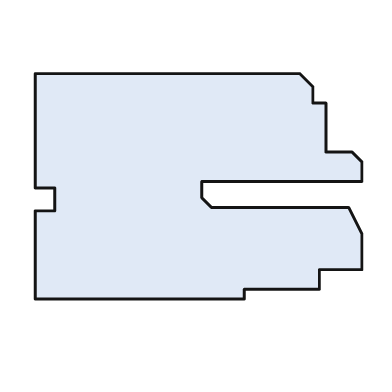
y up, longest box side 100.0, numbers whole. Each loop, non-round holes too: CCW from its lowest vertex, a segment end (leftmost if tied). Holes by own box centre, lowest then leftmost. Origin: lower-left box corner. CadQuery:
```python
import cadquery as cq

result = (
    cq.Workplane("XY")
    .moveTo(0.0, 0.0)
    .lineTo(64.0, 0.0)
    .lineTo(64.0, 3.0)
    .lineTo(87.0, 3.0)
    .lineTo(87.0, 9.0)
    .lineTo(100.0, 9.0)
    .lineTo(100.0, 20.0)
    .lineTo(96.0, 28.0)
    .lineTo(54.0, 28.0)
    .lineTo(51.0, 31.0)
    .lineTo(51.0, 36.0)
    .lineTo(100.0, 36.0)
    .lineTo(100.0, 42.0)
    .lineTo(97.0, 45.0)
    .lineTo(89.0, 45.0)
    .lineTo(89.0, 60.0)
    .lineTo(85.0, 60.0)
    .lineTo(85.0, 65.0)
    .lineTo(81.0, 69.0)
    .lineTo(0.0, 69.0)
    .lineTo(0.0, 34.0)
    .lineTo(6.0, 34.0)
    .lineTo(6.0, 27.0)
    .lineTo(0.0, 27.0)
    .close()
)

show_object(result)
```